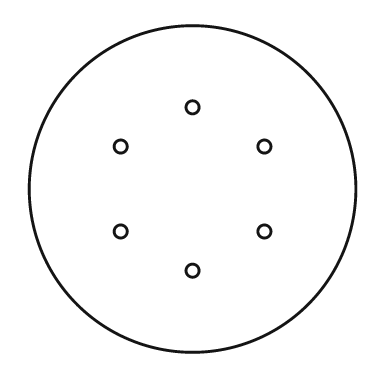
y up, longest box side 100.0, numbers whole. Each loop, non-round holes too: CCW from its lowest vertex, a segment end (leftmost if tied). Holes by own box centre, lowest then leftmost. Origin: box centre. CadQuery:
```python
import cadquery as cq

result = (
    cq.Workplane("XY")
    .moveTo(0.0, 0.0)
    .circle(50.0)
    .moveTo(0.0, -25.0)
    .circle(2.0)
    .moveTo(-22.0, -13.0)
    .circle(2.0)
    .moveTo(22.0, -13.0)
    .circle(2.0)
    .moveTo(-22.0, 13.0)
    .circle(2.0)
    .moveTo(22.0, 13.0)
    .circle(2.0)
    .moveTo(0.0, 25.0)
    .circle(2.0)
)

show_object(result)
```